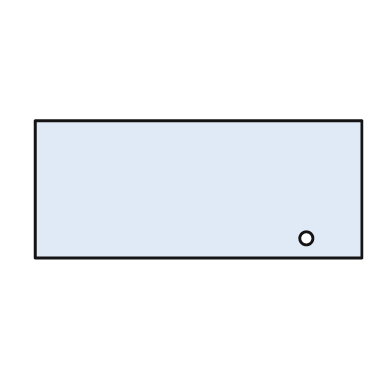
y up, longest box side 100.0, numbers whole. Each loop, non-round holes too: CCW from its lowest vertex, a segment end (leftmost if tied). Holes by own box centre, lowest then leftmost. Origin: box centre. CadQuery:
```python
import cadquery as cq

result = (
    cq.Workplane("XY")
    .moveTo(-50.0, -21.0)
    .lineTo(50.0, -21.0)
    .lineTo(50.0, 21.0)
    .lineTo(-50.0, 21.0)
    .close()
    .moveTo(33.0, -15.0)
    .circle(2.0)
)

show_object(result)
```